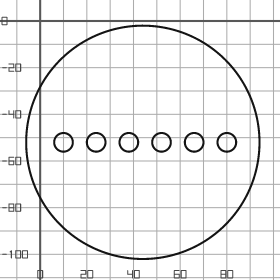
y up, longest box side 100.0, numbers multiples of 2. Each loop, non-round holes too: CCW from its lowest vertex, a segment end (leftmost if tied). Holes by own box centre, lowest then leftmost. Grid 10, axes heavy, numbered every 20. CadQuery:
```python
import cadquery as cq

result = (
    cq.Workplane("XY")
    .moveTo(44.0, -52.0)
    .circle(50.0)
    .moveTo(10.0, -52.0)
    .circle(4.0)
    .moveTo(24.0, -52.0)
    .circle(4.0)
    .moveTo(38.0, -52.0)
    .circle(4.0)
    .moveTo(52.0, -52.0)
    .circle(4.0)
    .moveTo(66.0, -52.0)
    .circle(4.0)
    .moveTo(80.0, -52.0)
    .circle(4.0)
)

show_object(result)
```